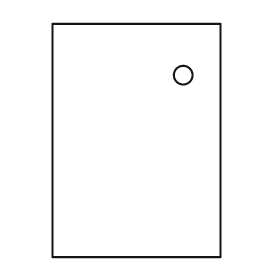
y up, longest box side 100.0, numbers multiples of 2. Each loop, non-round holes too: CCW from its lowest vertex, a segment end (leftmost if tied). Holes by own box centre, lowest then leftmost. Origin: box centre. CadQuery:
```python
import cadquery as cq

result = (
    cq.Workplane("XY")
    .moveTo(-36.0, -50.0)
    .lineTo(36.0, -50.0)
    .lineTo(36.0, 50.0)
    .lineTo(-36.0, 50.0)
    .close()
    .moveTo(20.0, 28.0)
    .circle(4.0)
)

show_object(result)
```